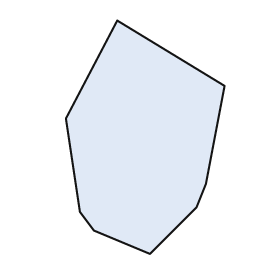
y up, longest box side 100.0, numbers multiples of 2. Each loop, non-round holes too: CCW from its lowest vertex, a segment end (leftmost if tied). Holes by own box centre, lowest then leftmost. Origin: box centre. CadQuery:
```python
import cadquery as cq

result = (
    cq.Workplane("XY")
    .moveTo(2.0, -50.0)
    .lineTo(22.0, -30.0)
    .lineTo(26.0, -20.0)
    .lineTo(34.0, 22.0)
    .lineTo(-12.0, 50.0)
    .lineTo(-34.0, 8.0)
    .lineTo(-28.0, -32.0)
    .lineTo(-22.0, -40.0)
    .close()
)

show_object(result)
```